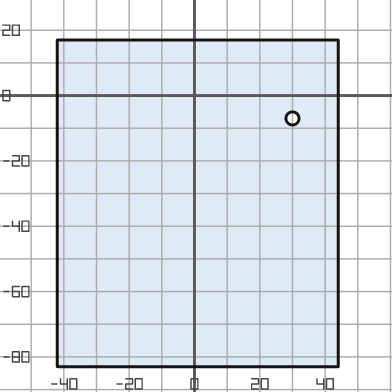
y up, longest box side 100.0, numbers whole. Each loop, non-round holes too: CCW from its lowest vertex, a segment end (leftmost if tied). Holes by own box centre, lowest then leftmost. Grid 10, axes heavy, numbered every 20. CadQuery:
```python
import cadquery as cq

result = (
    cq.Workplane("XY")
    .moveTo(-42.0, -83.0)
    .lineTo(44.0, -83.0)
    .lineTo(44.0, 17.0)
    .lineTo(-42.0, 17.0)
    .close()
    .moveTo(30.0, -7.0)
    .circle(2.0)
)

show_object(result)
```